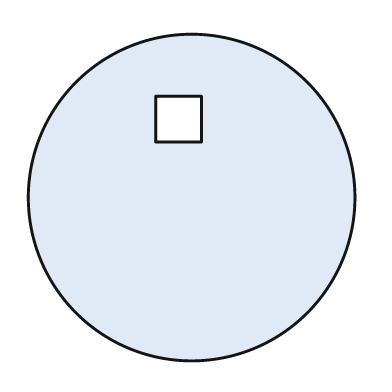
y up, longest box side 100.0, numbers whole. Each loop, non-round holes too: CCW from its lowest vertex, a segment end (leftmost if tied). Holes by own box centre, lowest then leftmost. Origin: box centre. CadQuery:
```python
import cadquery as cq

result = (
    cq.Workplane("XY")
    .moveTo(0.0, 0.0)
    .circle(50.0)
    .moveTo(-11.0, 17.0)
    .lineTo(3.0, 17.0)
    .lineTo(3.0, 31.0)
    .lineTo(-11.0, 31.0)
    .close()
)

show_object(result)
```